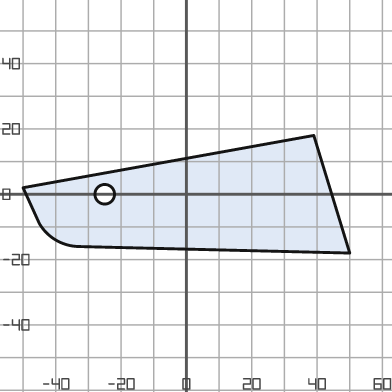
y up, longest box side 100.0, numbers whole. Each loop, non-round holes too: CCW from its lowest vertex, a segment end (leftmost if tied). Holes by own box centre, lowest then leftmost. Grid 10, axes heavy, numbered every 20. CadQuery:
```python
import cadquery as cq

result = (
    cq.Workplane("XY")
    .moveTo(50.0, -18.0)
    .lineTo(39.0, 18.0)
    .lineTo(-50.0, 2.0)
    .lineTo(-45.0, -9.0)
    .threePointArc((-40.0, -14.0), (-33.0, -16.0))
    .close()
    .moveTo(-25.0, 0.0)
    .circle(3.0)
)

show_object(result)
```